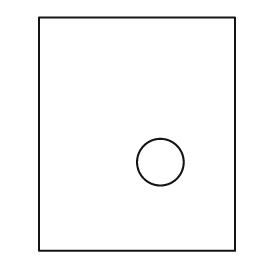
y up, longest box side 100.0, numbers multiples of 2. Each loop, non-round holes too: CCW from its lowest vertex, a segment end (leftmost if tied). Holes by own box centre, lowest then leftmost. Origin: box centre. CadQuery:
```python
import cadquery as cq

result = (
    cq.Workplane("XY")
    .moveTo(-42.0, -50.0)
    .lineTo(42.0, -50.0)
    .lineTo(42.0, 50.0)
    .lineTo(-42.0, 50.0)
    .close()
    .moveTo(10.0, -12.0)
    .circle(10.0)
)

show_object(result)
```